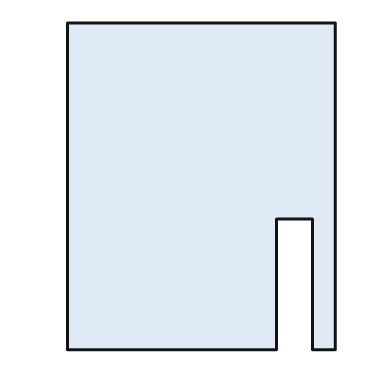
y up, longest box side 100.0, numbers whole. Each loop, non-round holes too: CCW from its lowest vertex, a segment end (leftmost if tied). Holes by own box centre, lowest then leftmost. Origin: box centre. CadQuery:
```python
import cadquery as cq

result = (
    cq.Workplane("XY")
    .moveTo(-41.0, -50.0)
    .lineTo(23.0, -50.0)
    .lineTo(23.0, -10.0)
    .lineTo(34.0, -10.0)
    .lineTo(34.0, -50.0)
    .lineTo(41.0, -50.0)
    .lineTo(41.0, 50.0)
    .lineTo(-41.0, 50.0)
    .close()
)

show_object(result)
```